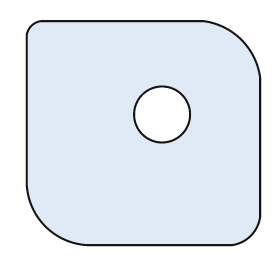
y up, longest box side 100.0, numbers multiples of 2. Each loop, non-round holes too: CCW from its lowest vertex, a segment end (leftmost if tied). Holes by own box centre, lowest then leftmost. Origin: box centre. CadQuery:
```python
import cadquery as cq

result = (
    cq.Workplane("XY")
    .moveTo(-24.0, -48.0)
    .lineTo(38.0, -48.0)
    .threePointArc((46.0, -44.0), (50.0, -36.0))
    .lineTo(50.0, 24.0)
    .threePointArc((42.0, 40.0), (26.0, 48.0))
    .lineTo(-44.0, 48.0)
    .threePointArc((-48.0, 46.0), (-50.0, 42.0))
    .lineTo(-50.0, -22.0)
    .threePointArc((-42.0, -40.0), (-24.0, -48.0))
    .close()
    .moveTo(8.0, 8.0)
    .circle(12.0)
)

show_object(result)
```